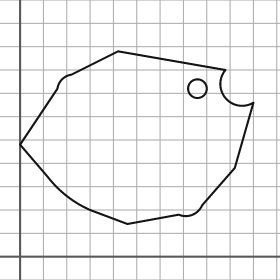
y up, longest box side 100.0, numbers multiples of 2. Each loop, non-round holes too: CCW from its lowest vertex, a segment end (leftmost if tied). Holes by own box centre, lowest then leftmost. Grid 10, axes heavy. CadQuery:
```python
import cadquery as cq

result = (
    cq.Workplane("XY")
    .moveTo(46.0, 14.0)
    .lineTo(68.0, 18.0)
    .threePointArc((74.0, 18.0), (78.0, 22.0))
    .lineTo(92.0, 38.0)
    .lineTo(100.0, 66.0)
    .threePointArc((88.0, 68.0), (88.0, 80.0))
    .lineTo(42.0, 88.0)
    .lineTo(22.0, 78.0)
    .threePointArc((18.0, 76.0), (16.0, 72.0))
    .lineTo(0.0, 48.0)
    .lineTo(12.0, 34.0)
    .threePointArc((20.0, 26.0), (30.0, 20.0))
    .close()
    .moveTo(76.0, 72.0)
    .circle(4.0)
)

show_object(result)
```